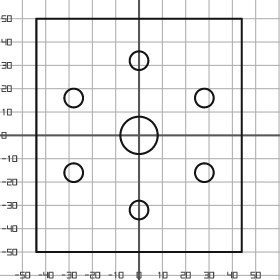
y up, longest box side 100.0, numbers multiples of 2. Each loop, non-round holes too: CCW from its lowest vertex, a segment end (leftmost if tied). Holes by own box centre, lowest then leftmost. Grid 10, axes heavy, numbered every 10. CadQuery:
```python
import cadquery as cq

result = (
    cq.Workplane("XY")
    .moveTo(-44.0, -50.0)
    .lineTo(44.0, -50.0)
    .lineTo(44.0, 50.0)
    .lineTo(-44.0, 50.0)
    .close()
    .moveTo(0.0, -32.0)
    .circle(4.0)
    .moveTo(-28.0, -16.0)
    .circle(4.0)
    .moveTo(28.0, -16.0)
    .circle(4.0)
    .moveTo(0.0, 0.0)
    .circle(8.0)
    .moveTo(-28.0, 16.0)
    .circle(4.0)
    .moveTo(28.0, 16.0)
    .circle(4.0)
    .moveTo(0.0, 32.0)
    .circle(4.0)
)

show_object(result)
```